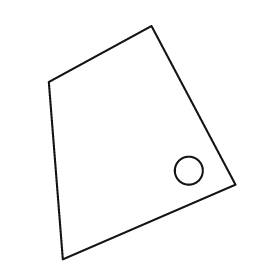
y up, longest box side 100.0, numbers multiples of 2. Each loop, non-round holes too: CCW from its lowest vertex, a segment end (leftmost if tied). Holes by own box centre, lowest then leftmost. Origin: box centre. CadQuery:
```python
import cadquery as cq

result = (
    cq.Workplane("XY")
    .moveTo(-34.0, -50.0)
    .lineTo(40.0, -18.0)
    .lineTo(4.0, 50.0)
    .lineTo(-40.0, 26.0)
    .close()
    .moveTo(20.0, -12.0)
    .circle(6.0)
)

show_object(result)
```